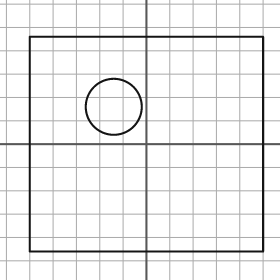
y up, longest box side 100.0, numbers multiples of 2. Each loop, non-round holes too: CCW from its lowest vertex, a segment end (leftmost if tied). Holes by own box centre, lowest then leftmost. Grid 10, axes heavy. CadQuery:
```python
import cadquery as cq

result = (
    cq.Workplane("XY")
    .moveTo(-50.0, -46.0)
    .lineTo(50.0, -46.0)
    .lineTo(50.0, 46.0)
    .lineTo(-50.0, 46.0)
    .close()
    .moveTo(-14.0, 16.0)
    .circle(12.0)
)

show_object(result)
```